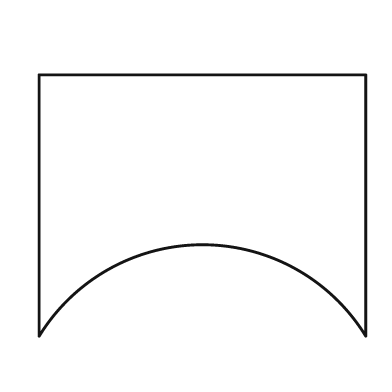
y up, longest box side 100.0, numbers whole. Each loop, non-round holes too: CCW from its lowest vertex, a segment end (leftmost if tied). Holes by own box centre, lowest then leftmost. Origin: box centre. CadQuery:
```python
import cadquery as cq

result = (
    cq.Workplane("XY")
    .moveTo(-50.0, -40.0)
    .threePointArc((0.0, -12.0), (50.0, -40.0))
    .lineTo(50.0, 40.0)
    .lineTo(-50.0, 40.0)
    .close()
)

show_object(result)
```